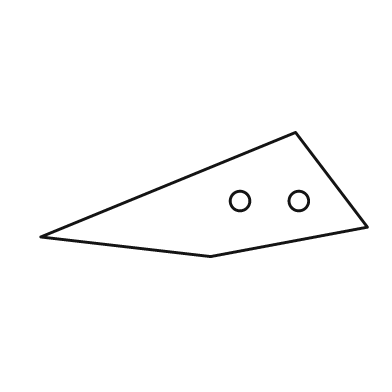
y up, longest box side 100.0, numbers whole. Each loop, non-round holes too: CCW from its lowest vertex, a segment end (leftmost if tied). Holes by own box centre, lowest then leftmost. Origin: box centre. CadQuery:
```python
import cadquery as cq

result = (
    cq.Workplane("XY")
    .moveTo(2.0, -19.0)
    .lineTo(50.0, -10.0)
    .lineTo(28.0, 19.0)
    .lineTo(-50.0, -13.0)
    .close()
    .moveTo(11.0, -2.0)
    .circle(3.0)
    .moveTo(29.0, -2.0)
    .circle(3.0)
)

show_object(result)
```